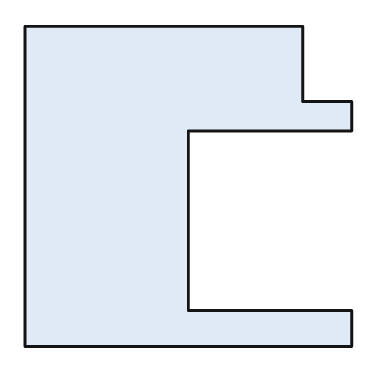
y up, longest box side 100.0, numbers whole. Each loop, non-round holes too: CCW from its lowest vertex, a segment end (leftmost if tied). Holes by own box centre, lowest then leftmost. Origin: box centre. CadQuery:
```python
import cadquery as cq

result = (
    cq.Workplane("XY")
    .moveTo(-50.0, -49.0)
    .lineTo(50.0, -49.0)
    .lineTo(50.0, -38.0)
    .lineTo(0.0, -38.0)
    .lineTo(0.0, 17.0)
    .lineTo(50.0, 17.0)
    .lineTo(50.0, 26.0)
    .lineTo(35.0, 26.0)
    .lineTo(35.0, 49.0)
    .lineTo(-50.0, 49.0)
    .close()
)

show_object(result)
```